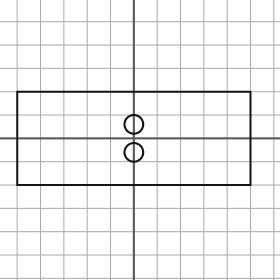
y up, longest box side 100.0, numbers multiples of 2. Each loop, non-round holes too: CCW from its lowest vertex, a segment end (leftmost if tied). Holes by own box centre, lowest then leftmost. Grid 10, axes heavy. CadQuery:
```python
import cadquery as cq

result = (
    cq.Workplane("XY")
    .moveTo(-50.0, -20.0)
    .lineTo(50.0, -20.0)
    .lineTo(50.0, 20.0)
    .lineTo(-50.0, 20.0)
    .close()
    .moveTo(0.0, -6.0)
    .circle(4.0)
    .moveTo(0.0, 6.0)
    .circle(4.0)
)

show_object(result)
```